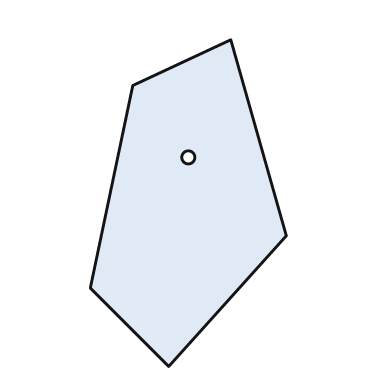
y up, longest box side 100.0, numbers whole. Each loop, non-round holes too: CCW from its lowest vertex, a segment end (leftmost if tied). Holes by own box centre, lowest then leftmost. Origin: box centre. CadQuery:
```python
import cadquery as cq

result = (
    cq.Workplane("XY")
    .moveTo(-6.0, -50.0)
    .lineTo(30.0, -10.0)
    .lineTo(13.0, 50.0)
    .lineTo(-17.0, 36.0)
    .lineTo(-30.0, -26.0)
    .close()
    .moveTo(0.0, 14.0)
    .circle(2.0)
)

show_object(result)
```